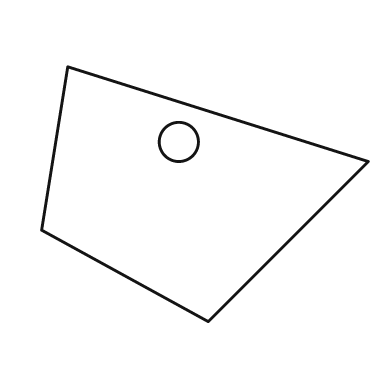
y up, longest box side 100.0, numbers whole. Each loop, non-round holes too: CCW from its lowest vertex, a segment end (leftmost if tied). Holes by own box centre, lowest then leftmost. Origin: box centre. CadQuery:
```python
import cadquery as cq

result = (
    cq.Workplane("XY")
    .moveTo(1.0, -39.0)
    .lineTo(50.0, 10.0)
    .lineTo(-42.0, 39.0)
    .lineTo(-50.0, -11.0)
    .close()
    .moveTo(-8.0, 16.0)
    .circle(6.0)
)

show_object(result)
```